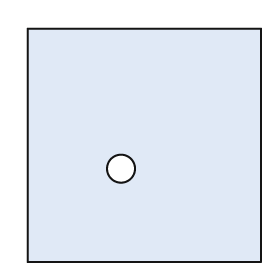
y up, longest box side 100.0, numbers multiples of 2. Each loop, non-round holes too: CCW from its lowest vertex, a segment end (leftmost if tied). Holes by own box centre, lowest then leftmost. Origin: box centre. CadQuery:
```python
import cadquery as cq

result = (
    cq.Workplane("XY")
    .moveTo(-50.0, -50.0)
    .lineTo(50.0, -50.0)
    .lineTo(50.0, 50.0)
    .lineTo(-50.0, 50.0)
    .close()
    .moveTo(-10.0, -10.0)
    .circle(6.0)
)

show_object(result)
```